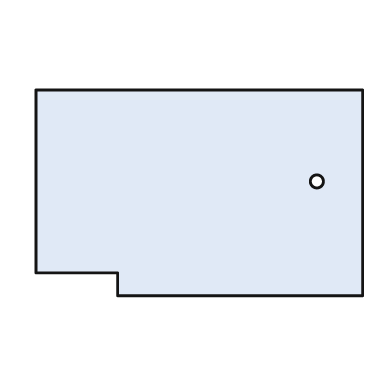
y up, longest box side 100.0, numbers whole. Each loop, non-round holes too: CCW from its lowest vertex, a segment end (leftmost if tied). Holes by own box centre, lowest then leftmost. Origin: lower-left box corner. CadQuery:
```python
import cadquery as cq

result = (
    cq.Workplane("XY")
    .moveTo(25.0, 0.0)
    .lineTo(100.0, 0.0)
    .lineTo(100.0, 63.0)
    .lineTo(0.0, 63.0)
    .lineTo(0.0, 7.0)
    .lineTo(25.0, 7.0)
    .close()
    .moveTo(86.0, 35.0)
    .circle(2.0)
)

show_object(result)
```